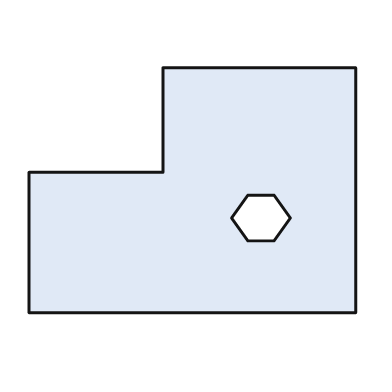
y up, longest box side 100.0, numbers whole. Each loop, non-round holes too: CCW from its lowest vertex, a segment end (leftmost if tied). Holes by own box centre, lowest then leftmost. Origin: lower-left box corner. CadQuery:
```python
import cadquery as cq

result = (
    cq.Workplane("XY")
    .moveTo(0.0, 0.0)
    .lineTo(100.0, 0.0)
    .lineTo(100.0, 75.0)
    .lineTo(41.0, 75.0)
    .lineTo(41.0, 43.0)
    .lineTo(0.0, 43.0)
    .close()
    .moveTo(67.0, 22.0)
    .lineTo(75.0, 22.0)
    .lineTo(80.0, 29.0)
    .lineTo(75.0, 36.0)
    .lineTo(67.0, 36.0)
    .lineTo(62.0, 29.0)
    .close()
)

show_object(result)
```